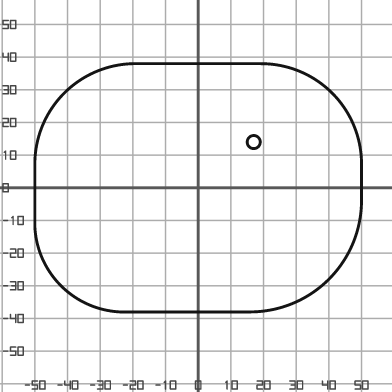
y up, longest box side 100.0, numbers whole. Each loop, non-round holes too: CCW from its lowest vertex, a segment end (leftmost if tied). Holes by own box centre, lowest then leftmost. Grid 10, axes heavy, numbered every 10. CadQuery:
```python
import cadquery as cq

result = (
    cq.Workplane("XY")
    .moveTo(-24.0, -38.0)
    .lineTo(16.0, -38.0)
    .threePointArc((40.0, -28.0), (50.0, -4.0))
    .lineTo(50.0, 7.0)
    .threePointArc((41.0, 29.0), (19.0, 38.0))
    .lineTo(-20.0, 38.0)
    .threePointArc((-41.0, 29.0), (-50.0, 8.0))
    .lineTo(-50.0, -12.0)
    .threePointArc((-42.0, -30.0), (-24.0, -38.0))
    .close()
    .moveTo(17.0, 14.0)
    .circle(2.0)
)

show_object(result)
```